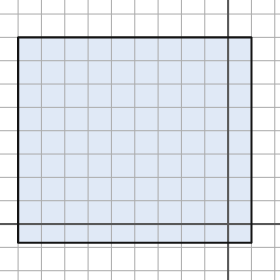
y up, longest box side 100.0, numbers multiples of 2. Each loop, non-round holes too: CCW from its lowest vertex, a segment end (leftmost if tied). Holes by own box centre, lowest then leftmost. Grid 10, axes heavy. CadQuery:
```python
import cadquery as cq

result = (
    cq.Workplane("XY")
    .moveTo(-90.0, -8.0)
    .lineTo(10.0, -8.0)
    .lineTo(10.0, 80.0)
    .lineTo(-90.0, 80.0)
    .close()
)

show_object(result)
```